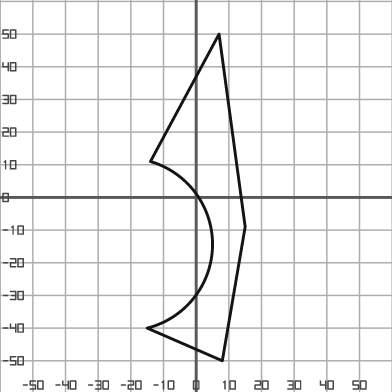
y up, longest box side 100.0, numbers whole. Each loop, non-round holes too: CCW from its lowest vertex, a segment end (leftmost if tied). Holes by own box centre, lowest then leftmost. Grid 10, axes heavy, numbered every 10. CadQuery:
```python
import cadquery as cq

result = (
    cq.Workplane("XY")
    .moveTo(8.0, -50.0)
    .lineTo(15.0, -9.0)
    .lineTo(7.0, 50.0)
    .lineTo(-14.0, 11.0)
    .threePointArc((5.0, -15.0), (-15.0, -40.0))
    .close()
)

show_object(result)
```